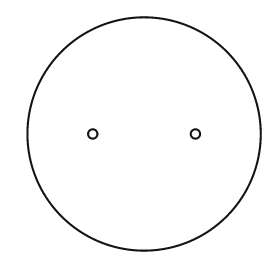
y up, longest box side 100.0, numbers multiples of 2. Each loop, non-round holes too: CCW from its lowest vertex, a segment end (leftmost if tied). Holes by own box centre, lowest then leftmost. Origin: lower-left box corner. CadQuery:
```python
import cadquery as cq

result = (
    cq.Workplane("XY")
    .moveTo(50.0, 50.0)
    .circle(50.0)
    .moveTo(28.0, 50.0)
    .circle(2.0)
    .moveTo(72.0, 50.0)
    .circle(2.0)
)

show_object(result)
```